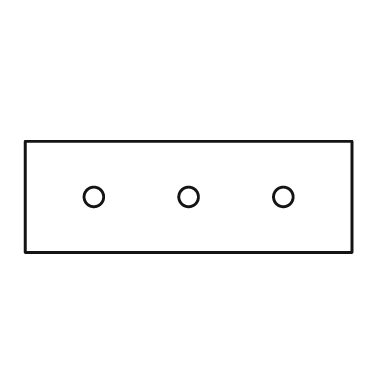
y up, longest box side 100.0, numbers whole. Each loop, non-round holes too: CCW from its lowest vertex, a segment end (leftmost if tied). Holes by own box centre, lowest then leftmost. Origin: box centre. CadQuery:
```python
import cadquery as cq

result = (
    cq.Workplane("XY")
    .moveTo(-50.0, -17.0)
    .lineTo(50.0, -17.0)
    .lineTo(50.0, 17.0)
    .lineTo(-50.0, 17.0)
    .close()
    .moveTo(-29.0, 0.0)
    .circle(3.0)
    .moveTo(0.0, 0.0)
    .circle(3.0)
    .moveTo(29.0, 0.0)
    .circle(3.0)
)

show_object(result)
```